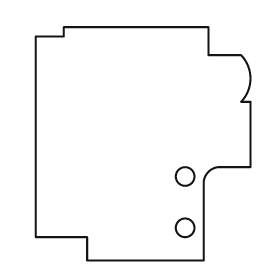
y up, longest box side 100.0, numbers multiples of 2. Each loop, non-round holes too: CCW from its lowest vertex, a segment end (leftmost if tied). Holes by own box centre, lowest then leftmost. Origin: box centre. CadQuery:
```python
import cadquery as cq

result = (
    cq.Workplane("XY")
    .moveTo(-24.0, -50.0)
    .lineTo(26.0, -50.0)
    .lineTo(26.0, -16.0)
    .threePointArc((28.0, -12.0), (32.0, -10.0))
    .lineTo(46.0, -10.0)
    .lineTo(46.0, 18.0)
    .lineTo(42.0, 18.0)
    .threePointArc((46.0, 28.0), (42.0, 38.0))
    .lineTo(28.0, 38.0)
    .lineTo(28.0, 50.0)
    .lineTo(-34.0, 50.0)
    .lineTo(-34.0, 46.0)
    .lineTo(-46.0, 46.0)
    .lineTo(-46.0, -40.0)
    .lineTo(-24.0, -40.0)
    .close()
    .moveTo(18.0, -36.0)
    .circle(4.0)
    .moveTo(18.0, -14.0)
    .circle(4.0)
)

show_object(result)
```